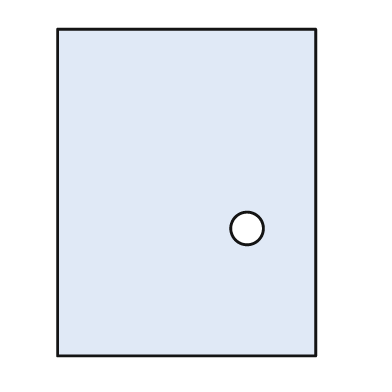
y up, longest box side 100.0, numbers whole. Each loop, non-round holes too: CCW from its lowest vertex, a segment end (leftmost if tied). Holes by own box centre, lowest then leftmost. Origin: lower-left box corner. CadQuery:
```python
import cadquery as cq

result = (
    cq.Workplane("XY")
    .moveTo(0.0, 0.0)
    .lineTo(79.0, 0.0)
    .lineTo(79.0, 100.0)
    .lineTo(0.0, 100.0)
    .close()
    .moveTo(58.0, 39.0)
    .circle(5.0)
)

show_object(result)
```